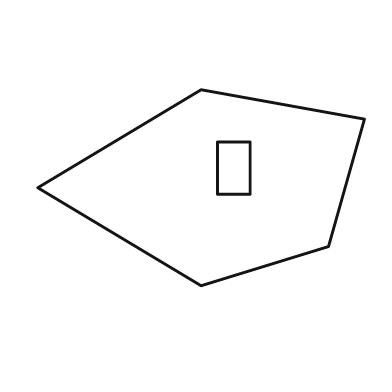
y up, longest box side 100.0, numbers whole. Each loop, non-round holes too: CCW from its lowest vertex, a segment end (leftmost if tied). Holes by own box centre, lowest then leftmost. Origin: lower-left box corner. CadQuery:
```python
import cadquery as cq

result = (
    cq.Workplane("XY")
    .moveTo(50.0, 0.0)
    .lineTo(89.0, 12.0)
    .lineTo(100.0, 51.0)
    .lineTo(50.0, 60.0)
    .lineTo(0.0, 30.0)
    .close()
    .moveTo(55.0, 28.0)
    .lineTo(65.0, 28.0)
    .lineTo(65.0, 44.0)
    .lineTo(55.0, 44.0)
    .close()
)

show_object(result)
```